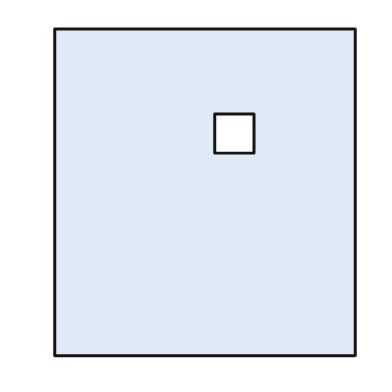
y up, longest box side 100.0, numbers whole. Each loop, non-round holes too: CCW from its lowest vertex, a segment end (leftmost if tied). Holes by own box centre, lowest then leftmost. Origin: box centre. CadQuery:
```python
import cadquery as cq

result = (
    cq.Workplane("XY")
    .moveTo(-46.0, -50.0)
    .lineTo(46.0, -50.0)
    .lineTo(46.0, 50.0)
    .lineTo(-46.0, 50.0)
    .close()
    .moveTo(3.0, 12.0)
    .lineTo(15.0, 12.0)
    .lineTo(15.0, 24.0)
    .lineTo(3.0, 24.0)
    .close()
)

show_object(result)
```